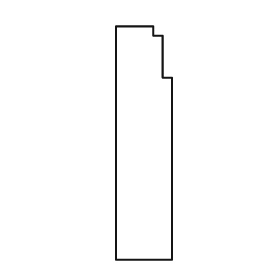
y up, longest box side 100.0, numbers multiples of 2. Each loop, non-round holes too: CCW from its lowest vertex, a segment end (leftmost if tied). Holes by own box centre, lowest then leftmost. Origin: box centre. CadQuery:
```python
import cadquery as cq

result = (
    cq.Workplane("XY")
    .moveTo(-12.0, -50.0)
    .lineTo(12.0, -50.0)
    .lineTo(12.0, 28.0)
    .lineTo(8.0, 28.0)
    .lineTo(8.0, 46.0)
    .lineTo(4.0, 46.0)
    .lineTo(4.0, 50.0)
    .lineTo(-12.0, 50.0)
    .close()
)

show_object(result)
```